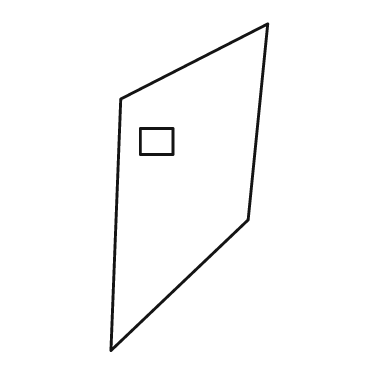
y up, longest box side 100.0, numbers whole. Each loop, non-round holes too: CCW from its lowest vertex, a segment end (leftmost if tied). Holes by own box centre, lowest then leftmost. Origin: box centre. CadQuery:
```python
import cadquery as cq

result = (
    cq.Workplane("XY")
    .moveTo(-24.0, -50.0)
    .lineTo(18.0, -10.0)
    .lineTo(24.0, 50.0)
    .lineTo(-21.0, 27.0)
    .close()
    .moveTo(-15.0, 10.0)
    .lineTo(-5.0, 10.0)
    .lineTo(-5.0, 18.0)
    .lineTo(-15.0, 18.0)
    .close()
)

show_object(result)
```